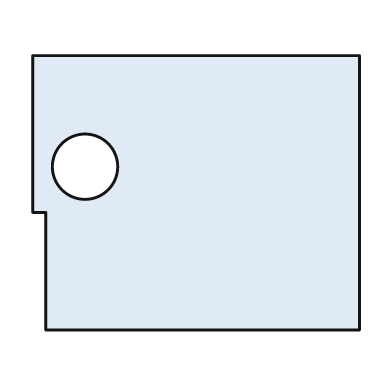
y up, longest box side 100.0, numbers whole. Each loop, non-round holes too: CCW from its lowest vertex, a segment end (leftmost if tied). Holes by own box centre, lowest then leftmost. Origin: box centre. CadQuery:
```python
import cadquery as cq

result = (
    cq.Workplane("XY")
    .moveTo(-46.0, -42.0)
    .lineTo(50.0, -42.0)
    .lineTo(50.0, 42.0)
    .lineTo(-50.0, 42.0)
    .lineTo(-50.0, -6.0)
    .lineTo(-46.0, -6.0)
    .close()
    .moveTo(-34.0, 8.0)
    .circle(10.0)
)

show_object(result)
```